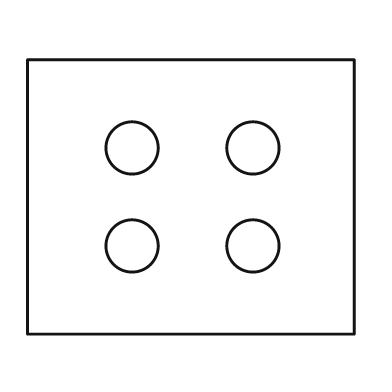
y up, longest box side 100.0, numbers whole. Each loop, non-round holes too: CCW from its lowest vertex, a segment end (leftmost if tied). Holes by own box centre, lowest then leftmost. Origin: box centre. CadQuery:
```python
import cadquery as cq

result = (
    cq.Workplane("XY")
    .moveTo(-50.0, -42.0)
    .lineTo(50.0, -42.0)
    .lineTo(50.0, 42.0)
    .lineTo(-50.0, 42.0)
    .close()
    .moveTo(-18.0, -15.0)
    .circle(8.0)
    .moveTo(19.0, -15.0)
    .circle(8.0)
    .moveTo(-18.0, 15.0)
    .circle(8.0)
    .moveTo(19.0, 15.0)
    .circle(8.0)
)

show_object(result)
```